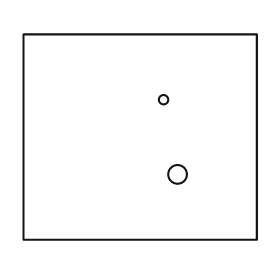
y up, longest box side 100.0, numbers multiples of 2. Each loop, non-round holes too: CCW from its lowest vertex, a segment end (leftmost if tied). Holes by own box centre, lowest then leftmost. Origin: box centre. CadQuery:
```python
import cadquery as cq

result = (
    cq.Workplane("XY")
    .moveTo(-50.0, -44.0)
    .lineTo(50.0, -44.0)
    .lineTo(50.0, 44.0)
    .lineTo(-50.0, 44.0)
    .close()
    .moveTo(16.0, -16.0)
    .circle(4.0)
    .moveTo(10.0, 16.0)
    .circle(2.0)
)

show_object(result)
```